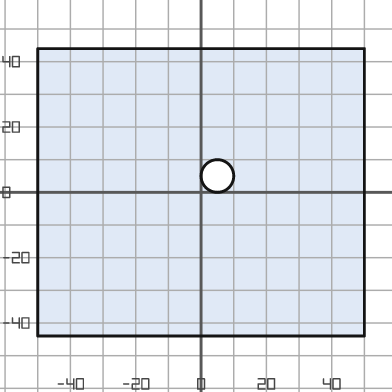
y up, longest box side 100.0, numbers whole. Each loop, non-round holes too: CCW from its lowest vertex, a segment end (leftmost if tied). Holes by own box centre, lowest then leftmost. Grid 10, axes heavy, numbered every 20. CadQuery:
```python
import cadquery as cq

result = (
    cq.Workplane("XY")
    .moveTo(-50.0, -44.0)
    .lineTo(50.0, -44.0)
    .lineTo(50.0, 44.0)
    .lineTo(-50.0, 44.0)
    .close()
    .moveTo(5.0, 5.0)
    .circle(5.0)
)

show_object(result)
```